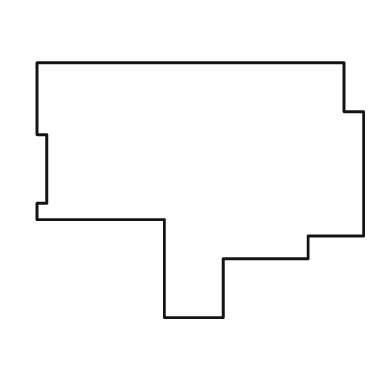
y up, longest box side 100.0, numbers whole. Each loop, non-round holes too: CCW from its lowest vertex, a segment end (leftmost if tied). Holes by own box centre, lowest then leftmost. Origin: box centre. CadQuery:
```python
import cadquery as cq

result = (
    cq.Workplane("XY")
    .moveTo(-11.0, -39.0)
    .lineTo(7.0, -39.0)
    .lineTo(7.0, -21.0)
    .lineTo(33.0, -21.0)
    .lineTo(33.0, -14.0)
    .lineTo(50.0, -14.0)
    .lineTo(50.0, 24.0)
    .lineTo(44.0, 24.0)
    .lineTo(44.0, 39.0)
    .lineTo(-50.0, 39.0)
    .lineTo(-50.0, 17.0)
    .lineTo(-47.0, 17.0)
    .lineTo(-47.0, -4.0)
    .lineTo(-50.0, -4.0)
    .lineTo(-50.0, -9.0)
    .lineTo(-11.0, -9.0)
    .close()
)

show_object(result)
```